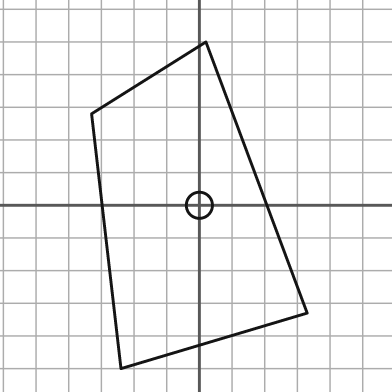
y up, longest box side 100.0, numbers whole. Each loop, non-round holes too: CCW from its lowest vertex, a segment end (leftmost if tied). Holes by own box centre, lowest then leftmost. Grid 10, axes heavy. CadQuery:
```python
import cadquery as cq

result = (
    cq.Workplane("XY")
    .moveTo(-24.0, -50.0)
    .lineTo(33.0, -33.0)
    .lineTo(2.0, 50.0)
    .lineTo(-33.0, 28.0)
    .close()
    .moveTo(0.0, 0.0)
    .circle(4.0)
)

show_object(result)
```